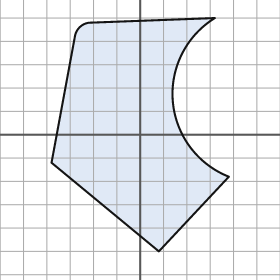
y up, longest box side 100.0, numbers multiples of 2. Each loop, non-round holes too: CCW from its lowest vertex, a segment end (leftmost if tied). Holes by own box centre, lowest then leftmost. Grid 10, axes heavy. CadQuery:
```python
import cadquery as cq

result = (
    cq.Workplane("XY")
    .moveTo(8.0, -50.0)
    .lineTo(38.0, -18.0)
    .threePointArc((14.0, 14.0), (32.0, 50.0))
    .lineTo(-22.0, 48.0)
    .threePointArc((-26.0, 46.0), (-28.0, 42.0))
    .lineTo(-38.0, -12.0)
    .close()
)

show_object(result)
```